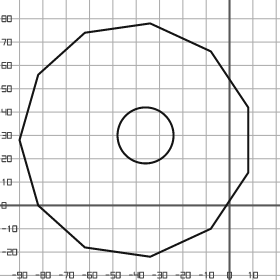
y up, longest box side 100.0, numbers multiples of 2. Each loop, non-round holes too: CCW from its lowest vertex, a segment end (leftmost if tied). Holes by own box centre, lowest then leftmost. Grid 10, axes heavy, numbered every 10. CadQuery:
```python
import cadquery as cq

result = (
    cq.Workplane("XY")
    .moveTo(-34.0, -22.0)
    .lineTo(-8.0, -10.0)
    .lineTo(8.0, 14.0)
    .lineTo(8.0, 42.0)
    .lineTo(-8.0, 66.0)
    .lineTo(-34.0, 78.0)
    .lineTo(-62.0, 74.0)
    .lineTo(-82.0, 56.0)
    .lineTo(-90.0, 28.0)
    .lineTo(-82.0, 0.0)
    .lineTo(-62.0, -18.0)
    .close()
    .moveTo(-36.0, 30.0)
    .circle(12.0)
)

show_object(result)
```